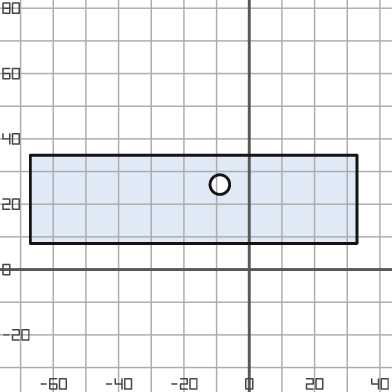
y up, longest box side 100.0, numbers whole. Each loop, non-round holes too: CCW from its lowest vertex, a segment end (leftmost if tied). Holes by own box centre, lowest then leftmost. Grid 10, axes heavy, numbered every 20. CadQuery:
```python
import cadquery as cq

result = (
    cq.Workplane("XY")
    .moveTo(-67.0, 8.0)
    .lineTo(33.0, 8.0)
    .lineTo(33.0, 35.0)
    .lineTo(-67.0, 35.0)
    .close()
    .moveTo(-9.0, 26.0)
    .circle(3.0)
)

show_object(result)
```